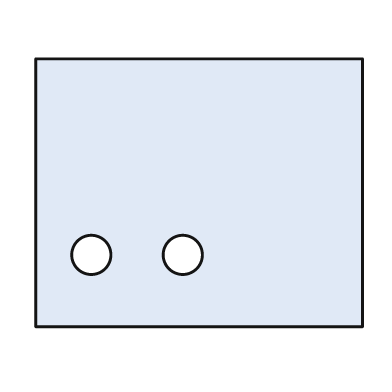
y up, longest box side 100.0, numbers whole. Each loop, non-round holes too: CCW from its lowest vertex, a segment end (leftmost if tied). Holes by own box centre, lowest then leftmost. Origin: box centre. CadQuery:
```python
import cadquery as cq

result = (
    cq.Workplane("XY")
    .moveTo(-50.0, -41.0)
    .lineTo(50.0, -41.0)
    .lineTo(50.0, 41.0)
    .lineTo(-50.0, 41.0)
    .close()
    .moveTo(-33.0, -19.0)
    .circle(6.0)
    .moveTo(-5.0, -19.0)
    .circle(6.0)
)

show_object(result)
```